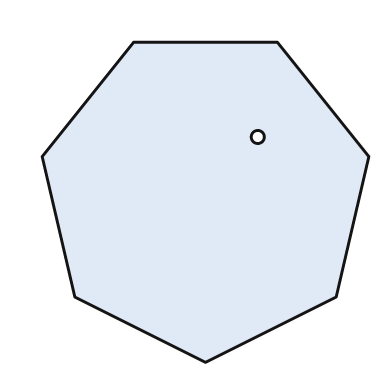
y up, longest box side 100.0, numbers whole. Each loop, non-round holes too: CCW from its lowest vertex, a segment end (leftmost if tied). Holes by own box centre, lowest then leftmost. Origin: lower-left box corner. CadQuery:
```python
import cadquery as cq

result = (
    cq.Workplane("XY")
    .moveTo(50.0, 0.0)
    .lineTo(90.0, 20.0)
    .lineTo(100.0, 63.0)
    .lineTo(72.0, 98.0)
    .lineTo(28.0, 98.0)
    .lineTo(0.0, 63.0)
    .lineTo(10.0, 20.0)
    .close()
    .moveTo(66.0, 69.0)
    .circle(2.0)
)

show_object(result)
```